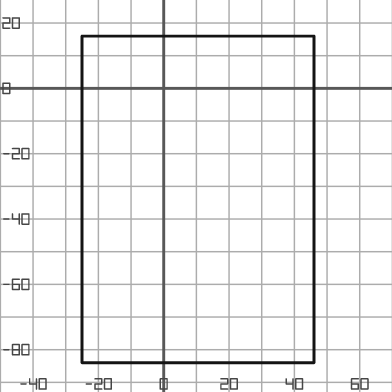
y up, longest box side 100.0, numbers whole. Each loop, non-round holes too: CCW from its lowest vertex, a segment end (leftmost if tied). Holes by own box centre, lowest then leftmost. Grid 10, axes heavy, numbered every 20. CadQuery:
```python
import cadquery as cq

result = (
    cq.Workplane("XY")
    .moveTo(-25.0, -84.0)
    .lineTo(46.0, -84.0)
    .lineTo(46.0, 16.0)
    .lineTo(-25.0, 16.0)
    .close()
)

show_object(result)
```